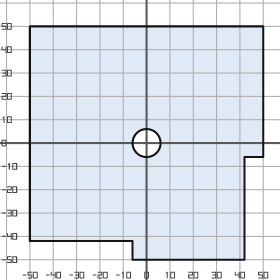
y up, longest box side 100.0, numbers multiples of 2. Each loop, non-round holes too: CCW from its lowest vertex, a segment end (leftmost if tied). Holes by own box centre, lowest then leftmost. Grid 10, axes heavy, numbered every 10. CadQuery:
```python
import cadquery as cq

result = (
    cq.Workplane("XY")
    .moveTo(-6.0, -50.0)
    .lineTo(42.0, -50.0)
    .lineTo(42.0, -6.0)
    .lineTo(50.0, -6.0)
    .lineTo(50.0, 50.0)
    .lineTo(-50.0, 50.0)
    .lineTo(-50.0, -42.0)
    .lineTo(-6.0, -42.0)
    .close()
    .moveTo(0.0, 0.0)
    .circle(6.0)
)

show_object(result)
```